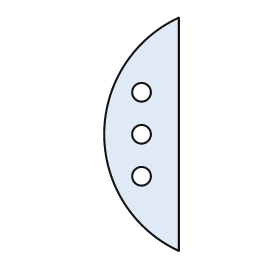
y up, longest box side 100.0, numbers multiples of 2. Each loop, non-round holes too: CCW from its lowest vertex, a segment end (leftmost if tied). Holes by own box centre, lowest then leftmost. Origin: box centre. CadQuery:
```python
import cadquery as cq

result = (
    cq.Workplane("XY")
    .moveTo(16.0, -50.0)
    .lineTo(16.0, 50.0)
    .threePointArc((-16.0, 0.0), (16.0, -50.0))
    .close()
    .moveTo(0.0, -18.0)
    .circle(4.0)
    .moveTo(0.0, 0.0)
    .circle(4.0)
    .moveTo(0.0, 18.0)
    .circle(4.0)
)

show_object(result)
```